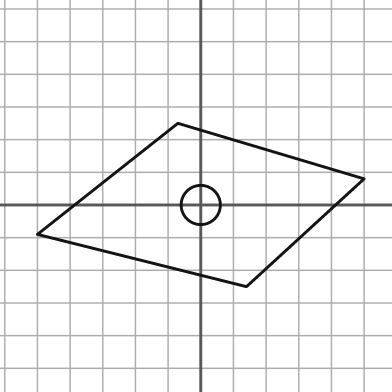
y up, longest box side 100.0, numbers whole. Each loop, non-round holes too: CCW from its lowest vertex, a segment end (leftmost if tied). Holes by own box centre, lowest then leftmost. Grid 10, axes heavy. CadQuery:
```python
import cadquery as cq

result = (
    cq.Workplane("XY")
    .moveTo(14.0, -25.0)
    .lineTo(50.0, 8.0)
    .lineTo(-7.0, 25.0)
    .lineTo(-50.0, -9.0)
    .close()
    .moveTo(0.0, 0.0)
    .circle(6.0)
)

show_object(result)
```